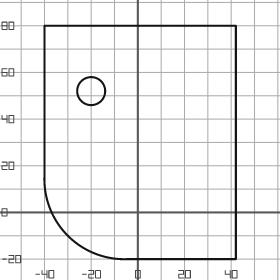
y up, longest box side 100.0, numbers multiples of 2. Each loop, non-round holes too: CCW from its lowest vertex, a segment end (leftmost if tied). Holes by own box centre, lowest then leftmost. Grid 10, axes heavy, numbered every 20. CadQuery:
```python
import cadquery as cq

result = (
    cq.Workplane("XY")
    .moveTo(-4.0, -20.0)
    .lineTo(42.0, -20.0)
    .lineTo(42.0, 80.0)
    .lineTo(-40.0, 80.0)
    .lineTo(-40.0, 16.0)
    .threePointArc((-30.0, -10.0), (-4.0, -20.0))
    .close()
    .moveTo(-20.0, 52.0)
    .circle(6.0)
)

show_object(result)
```